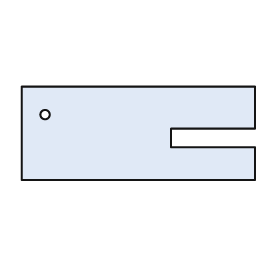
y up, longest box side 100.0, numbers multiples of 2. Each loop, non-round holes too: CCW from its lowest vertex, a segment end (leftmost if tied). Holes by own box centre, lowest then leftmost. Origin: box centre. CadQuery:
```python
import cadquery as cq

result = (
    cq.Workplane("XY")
    .moveTo(-50.0, -20.0)
    .lineTo(50.0, -20.0)
    .lineTo(50.0, -6.0)
    .lineTo(14.0, -6.0)
    .lineTo(14.0, 2.0)
    .lineTo(50.0, 2.0)
    .lineTo(50.0, 20.0)
    .lineTo(-50.0, 20.0)
    .close()
    .moveTo(-40.0, 8.0)
    .circle(2.0)
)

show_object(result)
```